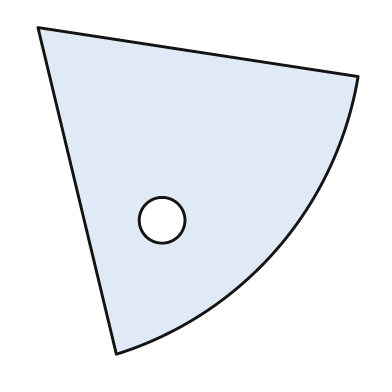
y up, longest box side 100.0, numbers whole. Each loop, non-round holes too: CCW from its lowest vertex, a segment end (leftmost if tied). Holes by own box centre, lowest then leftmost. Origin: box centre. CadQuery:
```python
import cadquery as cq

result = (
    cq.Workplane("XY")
    .moveTo(-25.0, -50.0)
    .threePointArc((24.0, -18.0), (49.0, 35.0))
    .lineTo(-49.0, 50.0)
    .close()
    .moveTo(-11.0, -9.0)
    .circle(7.0)
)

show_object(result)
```